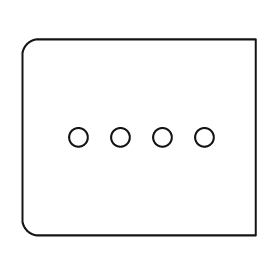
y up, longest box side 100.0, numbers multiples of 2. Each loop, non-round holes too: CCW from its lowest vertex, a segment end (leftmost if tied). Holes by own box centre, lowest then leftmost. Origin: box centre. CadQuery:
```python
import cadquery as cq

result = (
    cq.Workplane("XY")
    .moveTo(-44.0, -42.0)
    .lineTo(50.0, -42.0)
    .lineTo(50.0, 42.0)
    .lineTo(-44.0, 42.0)
    .threePointArc((-48.0, 40.0), (-50.0, 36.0))
    .lineTo(-50.0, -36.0)
    .threePointArc((-48.0, -40.0), (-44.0, -42.0))
    .close()
    .moveTo(-26.0, 0.0)
    .circle(4.0)
    .moveTo(-8.0, 0.0)
    .circle(4.0)
    .moveTo(10.0, 0.0)
    .circle(4.0)
    .moveTo(28.0, 0.0)
    .circle(4.0)
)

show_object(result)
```